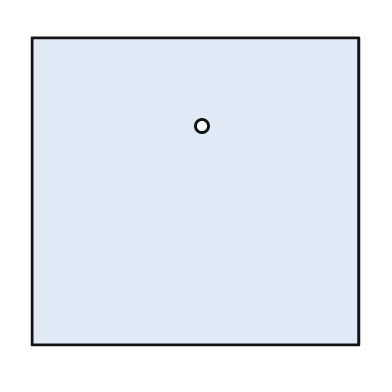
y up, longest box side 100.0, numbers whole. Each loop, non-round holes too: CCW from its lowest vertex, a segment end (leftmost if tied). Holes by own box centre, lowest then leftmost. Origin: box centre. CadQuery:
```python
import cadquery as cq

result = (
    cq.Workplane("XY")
    .moveTo(-50.0, -47.0)
    .lineTo(50.0, -47.0)
    .lineTo(50.0, 47.0)
    .lineTo(-50.0, 47.0)
    .close()
    .moveTo(2.0, 20.0)
    .circle(2.0)
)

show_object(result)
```